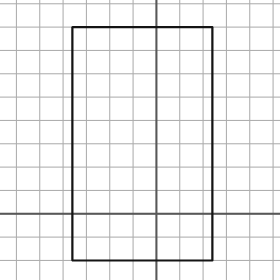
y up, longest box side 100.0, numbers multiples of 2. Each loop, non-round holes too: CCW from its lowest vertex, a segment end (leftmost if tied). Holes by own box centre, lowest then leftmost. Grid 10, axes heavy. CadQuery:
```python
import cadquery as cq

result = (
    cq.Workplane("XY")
    .moveTo(-36.0, -20.0)
    .lineTo(24.0, -20.0)
    .lineTo(24.0, 80.0)
    .lineTo(-36.0, 80.0)
    .close()
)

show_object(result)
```